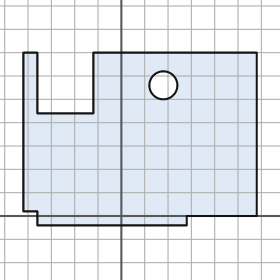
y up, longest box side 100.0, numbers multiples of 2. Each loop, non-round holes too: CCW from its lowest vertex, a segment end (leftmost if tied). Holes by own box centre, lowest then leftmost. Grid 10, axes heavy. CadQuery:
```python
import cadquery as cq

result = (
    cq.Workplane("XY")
    .moveTo(-36.0, -4.0)
    .lineTo(28.0, -4.0)
    .lineTo(28.0, 0.0)
    .lineTo(58.0, 0.0)
    .lineTo(58.0, 70.0)
    .lineTo(-12.0, 70.0)
    .lineTo(-12.0, 44.0)
    .lineTo(-36.0, 44.0)
    .lineTo(-36.0, 70.0)
    .lineTo(-42.0, 70.0)
    .lineTo(-42.0, 2.0)
    .lineTo(-36.0, 2.0)
    .close()
    .moveTo(18.0, 56.0)
    .circle(6.0)
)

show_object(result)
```